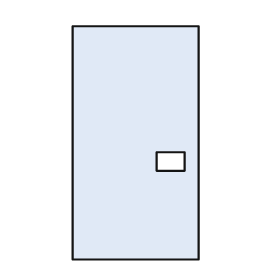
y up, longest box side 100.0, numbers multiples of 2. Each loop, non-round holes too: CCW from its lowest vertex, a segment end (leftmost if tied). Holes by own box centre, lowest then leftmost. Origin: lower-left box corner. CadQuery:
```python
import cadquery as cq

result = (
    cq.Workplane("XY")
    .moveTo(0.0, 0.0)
    .lineTo(54.0, 0.0)
    .lineTo(54.0, 100.0)
    .lineTo(0.0, 100.0)
    .close()
    .moveTo(36.0, 38.0)
    .lineTo(48.0, 38.0)
    .lineTo(48.0, 46.0)
    .lineTo(36.0, 46.0)
    .close()
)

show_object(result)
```